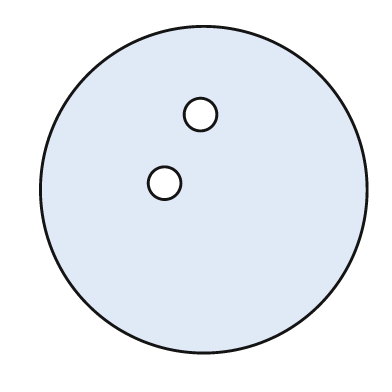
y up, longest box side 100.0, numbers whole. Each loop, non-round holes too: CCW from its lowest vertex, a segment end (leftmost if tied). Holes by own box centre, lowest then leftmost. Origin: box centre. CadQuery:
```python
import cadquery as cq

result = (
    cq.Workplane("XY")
    .moveTo(0.0, 0.0)
    .circle(50.0)
    .moveTo(-12.0, 2.0)
    .circle(5.0)
    .moveTo(-1.0, 23.0)
    .circle(5.0)
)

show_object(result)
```